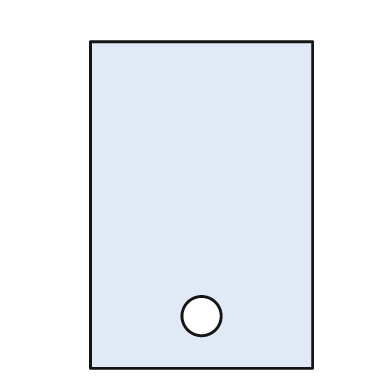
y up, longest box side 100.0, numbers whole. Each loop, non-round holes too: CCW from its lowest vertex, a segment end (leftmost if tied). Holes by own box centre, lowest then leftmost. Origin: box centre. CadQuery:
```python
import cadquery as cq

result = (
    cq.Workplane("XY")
    .moveTo(-34.0, -50.0)
    .lineTo(34.0, -50.0)
    .lineTo(34.0, 50.0)
    .lineTo(-34.0, 50.0)
    .close()
    .moveTo(0.0, -34.0)
    .circle(6.0)
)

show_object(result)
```